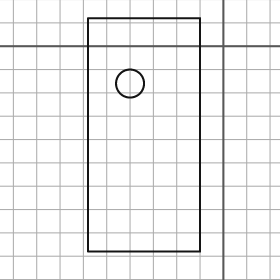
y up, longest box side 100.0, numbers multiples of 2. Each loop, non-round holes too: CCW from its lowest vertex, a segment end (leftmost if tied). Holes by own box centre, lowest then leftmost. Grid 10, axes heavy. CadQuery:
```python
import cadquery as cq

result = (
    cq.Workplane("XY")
    .moveTo(-58.0, -88.0)
    .lineTo(-10.0, -88.0)
    .lineTo(-10.0, 12.0)
    .lineTo(-58.0, 12.0)
    .close()
    .moveTo(-40.0, -16.0)
    .circle(6.0)
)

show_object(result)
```